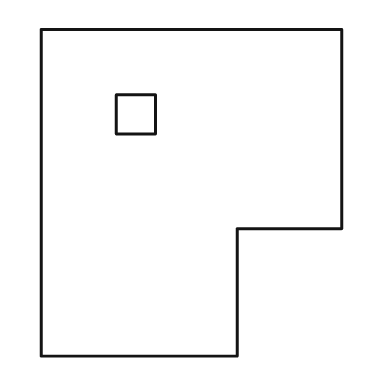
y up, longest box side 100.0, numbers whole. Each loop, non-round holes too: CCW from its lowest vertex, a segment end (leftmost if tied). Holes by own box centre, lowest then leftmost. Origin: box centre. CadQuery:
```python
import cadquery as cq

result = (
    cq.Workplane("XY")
    .moveTo(-46.0, -50.0)
    .lineTo(14.0, -50.0)
    .lineTo(14.0, -11.0)
    .lineTo(46.0, -11.0)
    .lineTo(46.0, 50.0)
    .lineTo(-46.0, 50.0)
    .close()
    .moveTo(-23.0, 18.0)
    .lineTo(-11.0, 18.0)
    .lineTo(-11.0, 30.0)
    .lineTo(-23.0, 30.0)
    .close()
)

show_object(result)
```